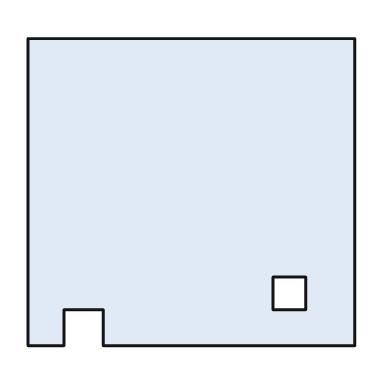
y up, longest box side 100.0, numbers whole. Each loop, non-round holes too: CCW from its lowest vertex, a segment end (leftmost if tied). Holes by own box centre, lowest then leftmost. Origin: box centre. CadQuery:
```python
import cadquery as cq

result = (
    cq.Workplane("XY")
    .moveTo(-50.0, -47.0)
    .lineTo(-39.0, -47.0)
    .lineTo(-39.0, -36.0)
    .lineTo(-27.0, -36.0)
    .lineTo(-27.0, -47.0)
    .lineTo(50.0, -47.0)
    .lineTo(50.0, 47.0)
    .lineTo(-50.0, 47.0)
    .close()
    .moveTo(25.0, -36.0)
    .lineTo(35.0, -36.0)
    .lineTo(35.0, -26.0)
    .lineTo(25.0, -26.0)
    .close()
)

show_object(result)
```